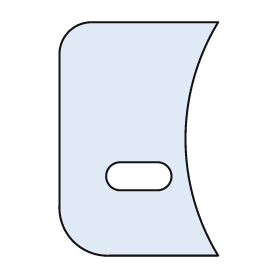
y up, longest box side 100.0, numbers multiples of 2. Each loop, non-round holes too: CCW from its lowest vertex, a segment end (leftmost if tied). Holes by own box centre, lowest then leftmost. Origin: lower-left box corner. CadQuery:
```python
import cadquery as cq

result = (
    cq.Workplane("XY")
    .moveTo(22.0, 0.0)
    .lineTo(68.0, 0.0)
    .threePointArc((54.0, 50.0), (68.0, 100.0))
    .lineTo(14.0, 100.0)
    .threePointArc((4.0, 96.0), (0.0, 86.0))
    .lineTo(0.0, 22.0)
    .threePointArc((6.0, 6.0), (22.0, 0.0))
    .close()
    .moveTo(26.0, 28.0)
    .lineTo(42.0, 28.0)
    .threePointArc((48.0, 34.0), (42.0, 40.0))
    .lineTo(26.0, 40.0)
    .threePointArc((20.0, 34.0), (26.0, 28.0))
    .close()
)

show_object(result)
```